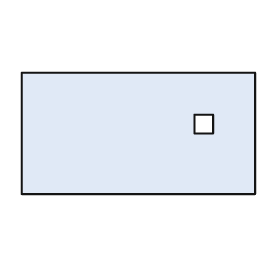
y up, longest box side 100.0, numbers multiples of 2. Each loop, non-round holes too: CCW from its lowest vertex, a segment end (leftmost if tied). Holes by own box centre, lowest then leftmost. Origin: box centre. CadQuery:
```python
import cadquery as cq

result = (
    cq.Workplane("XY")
    .moveTo(-50.0, -26.0)
    .lineTo(50.0, -26.0)
    .lineTo(50.0, 26.0)
    .lineTo(-50.0, 26.0)
    .close()
    .moveTo(24.0, 0.0)
    .lineTo(32.0, 0.0)
    .lineTo(32.0, 8.0)
    .lineTo(24.0, 8.0)
    .close()
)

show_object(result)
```